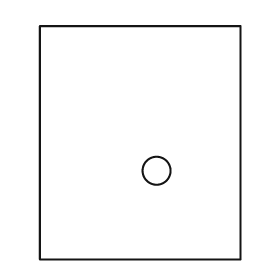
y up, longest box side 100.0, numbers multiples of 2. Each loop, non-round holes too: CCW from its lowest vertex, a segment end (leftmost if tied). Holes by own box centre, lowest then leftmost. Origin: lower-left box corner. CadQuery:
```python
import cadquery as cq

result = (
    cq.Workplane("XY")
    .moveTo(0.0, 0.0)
    .lineTo(86.0, 0.0)
    .lineTo(86.0, 100.0)
    .lineTo(0.0, 100.0)
    .close()
    .moveTo(50.0, 38.0)
    .circle(6.0)
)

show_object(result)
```